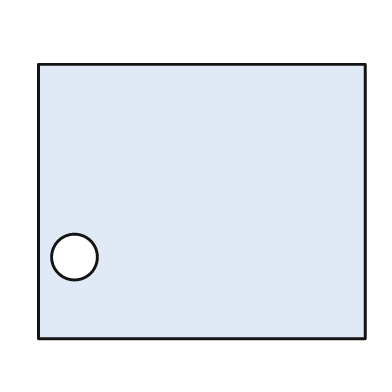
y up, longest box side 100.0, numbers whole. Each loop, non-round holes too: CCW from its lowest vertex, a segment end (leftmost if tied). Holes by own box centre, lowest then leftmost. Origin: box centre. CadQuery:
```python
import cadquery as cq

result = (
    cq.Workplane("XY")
    .moveTo(-50.0, -42.0)
    .lineTo(50.0, -42.0)
    .lineTo(50.0, 42.0)
    .lineTo(-50.0, 42.0)
    .close()
    .moveTo(-39.0, -17.0)
    .circle(7.0)
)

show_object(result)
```